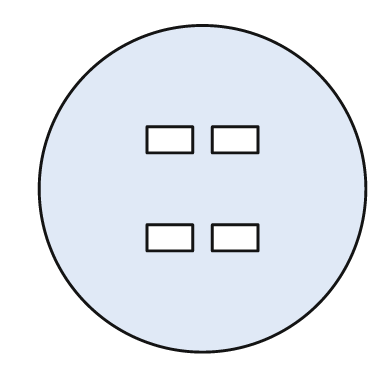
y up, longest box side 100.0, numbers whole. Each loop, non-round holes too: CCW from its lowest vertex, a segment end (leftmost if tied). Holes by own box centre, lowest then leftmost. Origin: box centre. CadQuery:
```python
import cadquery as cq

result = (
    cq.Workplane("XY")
    .moveTo(0.0, 0.0)
    .circle(50.0)
    .moveTo(-17.0, -19.0)
    .lineTo(-3.0, -19.0)
    .lineTo(-3.0, -11.0)
    .lineTo(-17.0, -11.0)
    .close()
    .moveTo(3.0, -19.0)
    .lineTo(17.0, -19.0)
    .lineTo(17.0, -11.0)
    .lineTo(3.0, -11.0)
    .close()
    .moveTo(-17.0, 11.0)
    .lineTo(-3.0, 11.0)
    .lineTo(-3.0, 19.0)
    .lineTo(-17.0, 19.0)
    .close()
    .moveTo(3.0, 11.0)
    .lineTo(17.0, 11.0)
    .lineTo(17.0, 19.0)
    .lineTo(3.0, 19.0)
    .close()
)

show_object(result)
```